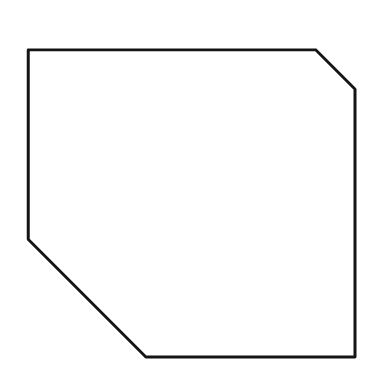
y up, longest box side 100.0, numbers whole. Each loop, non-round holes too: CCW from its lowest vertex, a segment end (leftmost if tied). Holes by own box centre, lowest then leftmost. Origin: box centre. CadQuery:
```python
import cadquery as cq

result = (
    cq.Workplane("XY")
    .moveTo(-14.0, -47.0)
    .lineTo(50.0, -47.0)
    .lineTo(50.0, 35.0)
    .lineTo(38.0, 47.0)
    .lineTo(-50.0, 47.0)
    .lineTo(-50.0, -11.0)
    .close()
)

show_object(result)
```